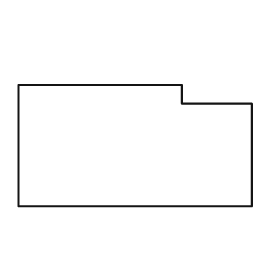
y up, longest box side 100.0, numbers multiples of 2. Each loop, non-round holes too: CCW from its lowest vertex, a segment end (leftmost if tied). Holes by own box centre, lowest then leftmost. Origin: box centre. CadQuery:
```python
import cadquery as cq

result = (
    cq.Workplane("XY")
    .moveTo(-50.0, -26.0)
    .lineTo(50.0, -26.0)
    .lineTo(50.0, 18.0)
    .lineTo(20.0, 18.0)
    .lineTo(20.0, 26.0)
    .lineTo(-50.0, 26.0)
    .close()
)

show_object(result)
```